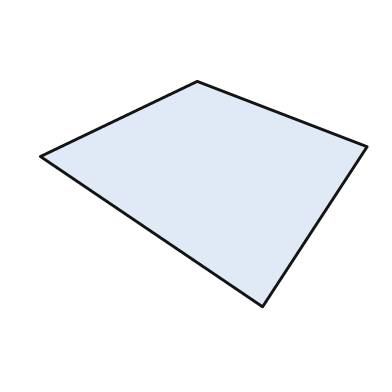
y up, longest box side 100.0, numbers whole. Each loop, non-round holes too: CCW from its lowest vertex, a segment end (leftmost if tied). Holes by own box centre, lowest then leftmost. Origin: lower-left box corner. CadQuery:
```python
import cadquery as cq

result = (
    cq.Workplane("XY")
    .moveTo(68.0, 0.0)
    .lineTo(100.0, 49.0)
    .lineTo(48.0, 69.0)
    .lineTo(0.0, 46.0)
    .close()
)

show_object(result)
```